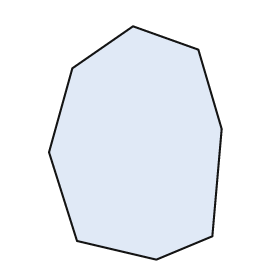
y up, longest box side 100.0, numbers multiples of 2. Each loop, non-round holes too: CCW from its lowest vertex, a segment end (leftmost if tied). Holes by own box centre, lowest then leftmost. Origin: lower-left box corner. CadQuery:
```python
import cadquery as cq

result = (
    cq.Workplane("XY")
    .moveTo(46.0, 0.0)
    .lineTo(70.0, 10.0)
    .lineTo(74.0, 56.0)
    .lineTo(64.0, 90.0)
    .lineTo(36.0, 100.0)
    .lineTo(10.0, 82.0)
    .lineTo(0.0, 46.0)
    .lineTo(12.0, 8.0)
    .close()
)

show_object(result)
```